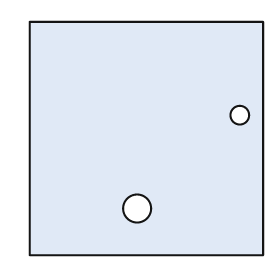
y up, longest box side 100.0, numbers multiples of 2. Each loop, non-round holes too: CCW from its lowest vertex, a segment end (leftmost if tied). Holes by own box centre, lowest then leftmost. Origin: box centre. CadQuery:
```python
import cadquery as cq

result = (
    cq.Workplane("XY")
    .moveTo(-50.0, -50.0)
    .lineTo(50.0, -50.0)
    .lineTo(50.0, 50.0)
    .lineTo(-50.0, 50.0)
    .close()
    .moveTo(-4.0, -30.0)
    .circle(6.0)
    .moveTo(40.0, 10.0)
    .circle(4.0)
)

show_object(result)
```